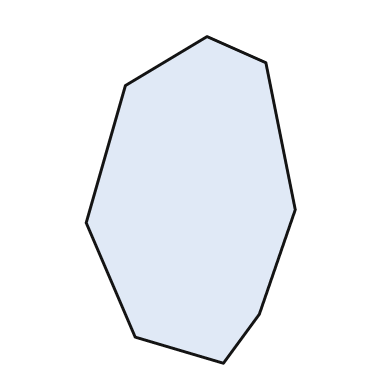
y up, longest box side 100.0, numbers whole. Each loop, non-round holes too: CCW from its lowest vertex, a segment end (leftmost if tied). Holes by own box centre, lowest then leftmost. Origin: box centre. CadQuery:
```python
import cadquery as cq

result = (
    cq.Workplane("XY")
    .moveTo(10.0, -50.0)
    .lineTo(21.0, -35.0)
    .lineTo(32.0, -3.0)
    .lineTo(23.0, 42.0)
    .lineTo(5.0, 50.0)
    .lineTo(-20.0, 35.0)
    .lineTo(-32.0, -7.0)
    .lineTo(-17.0, -42.0)
    .close()
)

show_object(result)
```